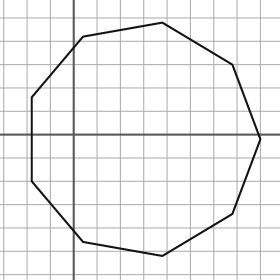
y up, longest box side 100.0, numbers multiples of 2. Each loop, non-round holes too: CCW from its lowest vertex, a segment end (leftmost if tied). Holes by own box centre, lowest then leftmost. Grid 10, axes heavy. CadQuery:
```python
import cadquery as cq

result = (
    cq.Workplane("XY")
    .moveTo(38.0, -52.0)
    .lineTo(68.0, -34.0)
    .lineTo(80.0, -2.0)
    .lineTo(68.0, 30.0)
    .lineTo(38.0, 48.0)
    .lineTo(4.0, 42.0)
    .lineTo(-18.0, 16.0)
    .lineTo(-18.0, -20.0)
    .lineTo(4.0, -46.0)
    .close()
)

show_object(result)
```